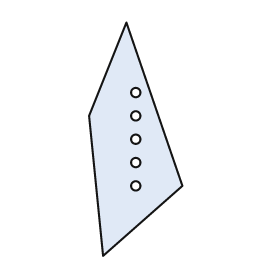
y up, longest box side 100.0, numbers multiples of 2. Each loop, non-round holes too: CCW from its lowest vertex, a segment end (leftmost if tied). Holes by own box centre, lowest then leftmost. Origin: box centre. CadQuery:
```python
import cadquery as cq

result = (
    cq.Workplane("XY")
    .moveTo(-14.0, -50.0)
    .lineTo(20.0, -20.0)
    .lineTo(-4.0, 50.0)
    .lineTo(-20.0, 10.0)
    .close()
    .moveTo(0.0, -20.0)
    .circle(2.0)
    .moveTo(0.0, -10.0)
    .circle(2.0)
    .moveTo(0.0, 0.0)
    .circle(2.0)
    .moveTo(0.0, 10.0)
    .circle(2.0)
    .moveTo(0.0, 20.0)
    .circle(2.0)
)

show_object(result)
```